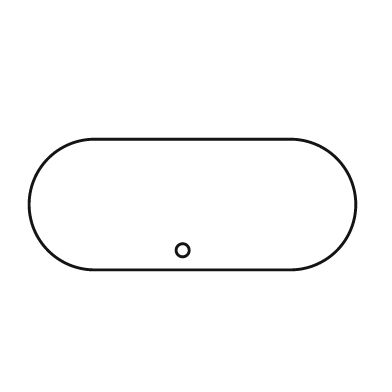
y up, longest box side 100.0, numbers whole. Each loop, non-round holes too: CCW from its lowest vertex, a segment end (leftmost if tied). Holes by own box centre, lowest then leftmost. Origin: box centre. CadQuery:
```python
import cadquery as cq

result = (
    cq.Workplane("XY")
    .moveTo(-30.0, -20.0)
    .lineTo(30.0, -20.0)
    .threePointArc((50.0, 0.0), (30.0, 20.0))
    .lineTo(-30.0, 20.0)
    .threePointArc((-50.0, 0.0), (-30.0, -20.0))
    .close()
    .moveTo(-3.0, -14.0)
    .circle(2.0)
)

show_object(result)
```